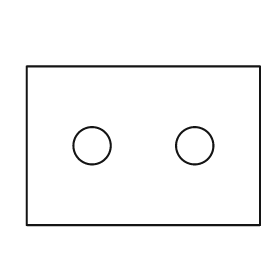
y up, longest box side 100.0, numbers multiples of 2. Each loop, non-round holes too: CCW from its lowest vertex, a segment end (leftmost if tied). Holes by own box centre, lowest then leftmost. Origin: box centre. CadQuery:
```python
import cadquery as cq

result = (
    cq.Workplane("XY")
    .moveTo(-50.0, -34.0)
    .lineTo(50.0, -34.0)
    .lineTo(50.0, 34.0)
    .lineTo(-50.0, 34.0)
    .close()
    .moveTo(-22.0, 0.0)
    .circle(8.0)
    .moveTo(22.0, 0.0)
    .circle(8.0)
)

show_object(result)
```